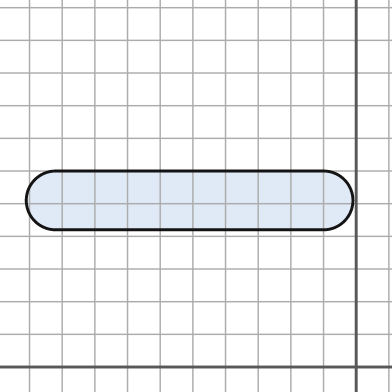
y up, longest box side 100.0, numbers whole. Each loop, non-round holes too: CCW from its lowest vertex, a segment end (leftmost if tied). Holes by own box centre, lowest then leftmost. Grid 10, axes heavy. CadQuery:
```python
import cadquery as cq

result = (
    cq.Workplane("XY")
    .moveTo(-92.0, 42.0)
    .lineTo(-10.0, 42.0)
    .threePointArc((-1.0, 51.0), (-10.0, 60.0))
    .lineTo(-92.0, 60.0)
    .threePointArc((-101.0, 51.0), (-92.0, 42.0))
    .close()
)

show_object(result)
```